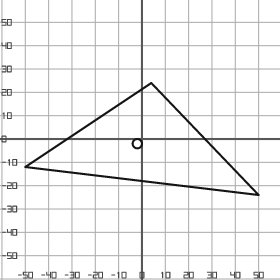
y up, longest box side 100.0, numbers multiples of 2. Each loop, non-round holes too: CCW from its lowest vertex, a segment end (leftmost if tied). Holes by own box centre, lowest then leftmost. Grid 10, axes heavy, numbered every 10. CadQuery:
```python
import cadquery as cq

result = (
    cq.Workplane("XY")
    .moveTo(50.0, -24.0)
    .lineTo(4.0, 24.0)
    .lineTo(-50.0, -12.0)
    .close()
    .moveTo(-2.0, -2.0)
    .circle(2.0)
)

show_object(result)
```